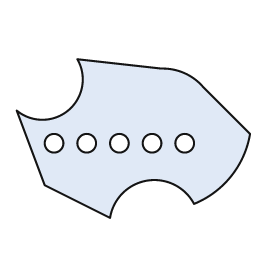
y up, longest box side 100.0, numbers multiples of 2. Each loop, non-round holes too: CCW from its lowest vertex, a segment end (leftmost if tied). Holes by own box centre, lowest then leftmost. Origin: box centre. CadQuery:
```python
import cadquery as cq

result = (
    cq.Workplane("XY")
    .moveTo(-10.0, -34.0)
    .threePointArc((6.0, -18.0), (26.0, -28.0))
    .threePointArc((42.0, -16.0), (50.0, 2.0))
    .lineTo(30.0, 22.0)
    .threePointArc((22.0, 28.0), (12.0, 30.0))
    .lineTo(-24.0, 34.0)
    .threePointArc((-28.0, 12.0), (-50.0, 12.0))
    .lineTo(-38.0, -20.0)
    .close()
    .moveTo(-34.0, -2.0)
    .circle(4.0)
    .moveTo(-20.0, -2.0)
    .circle(4.0)
    .moveTo(-6.0, -2.0)
    .circle(4.0)
    .moveTo(8.0, -2.0)
    .circle(4.0)
    .moveTo(22.0, -2.0)
    .circle(4.0)
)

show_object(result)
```